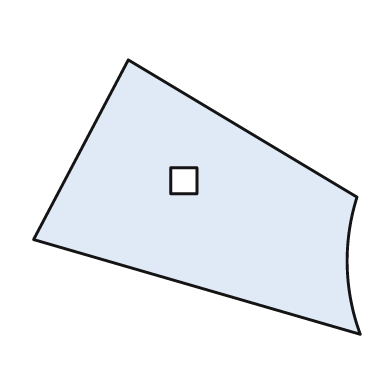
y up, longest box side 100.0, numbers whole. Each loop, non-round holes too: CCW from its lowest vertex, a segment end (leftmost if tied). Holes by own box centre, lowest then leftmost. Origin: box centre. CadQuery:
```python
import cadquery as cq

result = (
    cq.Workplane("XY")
    .moveTo(50.0, -42.0)
    .threePointArc((46.0, -21.0), (49.0, 0.0))
    .lineTo(-21.0, 42.0)
    .lineTo(-50.0, -13.0)
    .close()
    .moveTo(-8.0, 1.0)
    .lineTo(0.0, 1.0)
    .lineTo(0.0, 9.0)
    .lineTo(-8.0, 9.0)
    .close()
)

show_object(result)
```